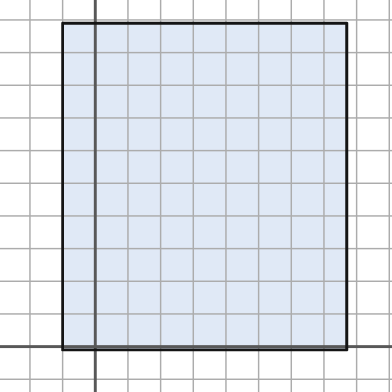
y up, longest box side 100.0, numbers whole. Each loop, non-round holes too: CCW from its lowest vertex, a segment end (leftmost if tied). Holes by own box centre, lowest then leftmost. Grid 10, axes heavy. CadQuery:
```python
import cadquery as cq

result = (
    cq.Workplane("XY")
    .moveTo(-10.0, -1.0)
    .lineTo(77.0, -1.0)
    .lineTo(77.0, 99.0)
    .lineTo(-10.0, 99.0)
    .close()
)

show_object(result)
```